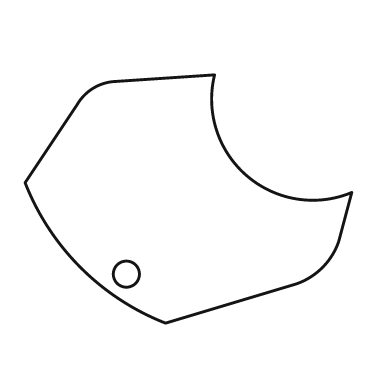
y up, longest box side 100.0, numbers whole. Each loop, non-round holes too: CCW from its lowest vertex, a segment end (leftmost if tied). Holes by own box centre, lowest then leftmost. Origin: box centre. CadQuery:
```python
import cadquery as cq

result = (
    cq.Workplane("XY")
    .moveTo(-7.0, -38.0)
    .lineTo(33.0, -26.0)
    .threePointArc((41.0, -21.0), (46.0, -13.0))
    .lineTo(50.0, 2.0)
    .threePointArc((18.0, 7.0), (8.0, 38.0))
    .lineTo(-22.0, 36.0)
    .threePointArc((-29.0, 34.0), (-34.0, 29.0))
    .lineTo(-50.0, 5.0)
    .threePointArc((-33.0, -21.0), (-7.0, -38.0))
    .close()
    .moveTo(-19.0, -23.0)
    .circle(4.0)
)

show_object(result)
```